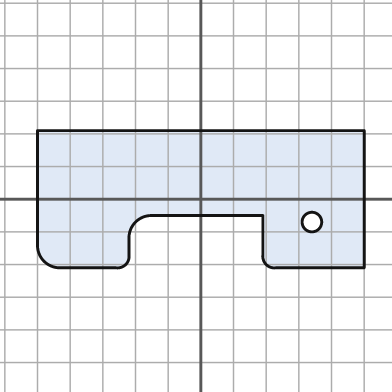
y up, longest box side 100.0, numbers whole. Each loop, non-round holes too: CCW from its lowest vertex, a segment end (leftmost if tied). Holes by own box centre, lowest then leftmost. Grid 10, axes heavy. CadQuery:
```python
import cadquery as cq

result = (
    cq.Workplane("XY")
    .moveTo(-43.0, -21.0)
    .lineTo(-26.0, -21.0)
    .threePointArc((-23.0, -20.0), (-22.0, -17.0))
    .lineTo(-22.0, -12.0)
    .threePointArc((-20.0, -7.0), (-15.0, -5.0))
    .lineTo(19.0, -5.0)
    .lineTo(19.0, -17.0)
    .threePointArc((20.0, -20.0), (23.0, -21.0))
    .lineTo(50.0, -21.0)
    .lineTo(50.0, 21.0)
    .lineTo(-50.0, 21.0)
    .lineTo(-50.0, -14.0)
    .threePointArc((-48.0, -19.0), (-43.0, -21.0))
    .close()
    .moveTo(34.0, -7.0)
    .circle(3.0)
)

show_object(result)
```